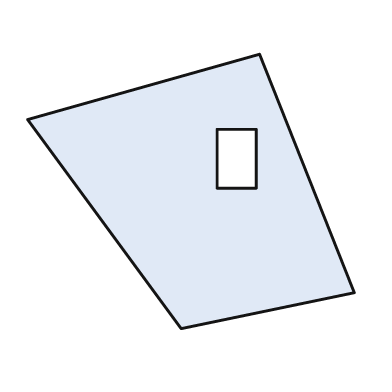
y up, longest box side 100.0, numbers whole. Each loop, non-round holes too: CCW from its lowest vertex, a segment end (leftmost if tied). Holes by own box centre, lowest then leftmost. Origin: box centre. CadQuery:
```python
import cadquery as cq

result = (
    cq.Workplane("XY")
    .moveTo(-3.0, -42.0)
    .lineTo(50.0, -31.0)
    .lineTo(21.0, 42.0)
    .lineTo(-50.0, 22.0)
    .close()
    .moveTo(8.0, 1.0)
    .lineTo(20.0, 1.0)
    .lineTo(20.0, 19.0)
    .lineTo(8.0, 19.0)
    .close()
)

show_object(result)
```